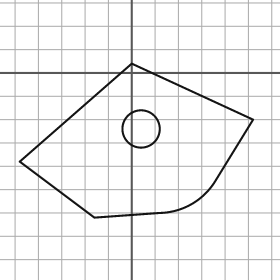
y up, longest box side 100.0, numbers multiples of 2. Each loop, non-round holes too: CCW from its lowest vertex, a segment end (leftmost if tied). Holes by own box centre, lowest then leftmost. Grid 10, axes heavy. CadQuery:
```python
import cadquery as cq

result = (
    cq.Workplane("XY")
    .moveTo(-16.0, -62.0)
    .lineTo(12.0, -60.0)
    .threePointArc((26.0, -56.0), (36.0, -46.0))
    .lineTo(52.0, -20.0)
    .lineTo(0.0, 4.0)
    .lineTo(-48.0, -38.0)
    .close()
    .moveTo(4.0, -24.0)
    .circle(8.0)
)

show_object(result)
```